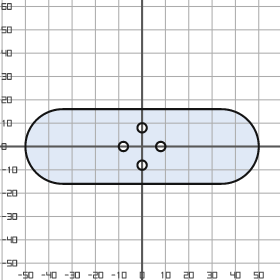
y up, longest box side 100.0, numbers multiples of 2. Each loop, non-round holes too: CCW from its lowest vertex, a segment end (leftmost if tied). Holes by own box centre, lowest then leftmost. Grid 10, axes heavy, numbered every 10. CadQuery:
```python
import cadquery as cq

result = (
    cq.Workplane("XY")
    .moveTo(-34.0, -16.0)
    .lineTo(34.0, -16.0)
    .threePointArc((50.0, 0.0), (34.0, 16.0))
    .lineTo(-34.0, 16.0)
    .threePointArc((-50.0, 0.0), (-34.0, -16.0))
    .close()
    .moveTo(0.0, -8.0)
    .circle(2.0)
    .moveTo(-8.0, 0.0)
    .circle(2.0)
    .moveTo(8.0, 0.0)
    .circle(2.0)
    .moveTo(0.0, 8.0)
    .circle(2.0)
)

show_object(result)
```